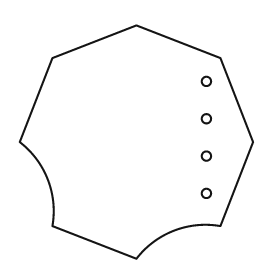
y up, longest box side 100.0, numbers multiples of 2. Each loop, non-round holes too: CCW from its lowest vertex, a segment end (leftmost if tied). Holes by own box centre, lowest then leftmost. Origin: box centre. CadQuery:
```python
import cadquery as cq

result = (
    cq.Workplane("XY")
    .moveTo(0.0, -50.0)
    .threePointArc((16.0, -38.0), (36.0, -36.0))
    .lineTo(50.0, 0.0)
    .lineTo(36.0, 36.0)
    .lineTo(0.0, 50.0)
    .lineTo(-36.0, 36.0)
    .lineTo(-50.0, 0.0)
    .threePointArc((-38.0, -16.0), (-36.0, -36.0))
    .close()
    .moveTo(30.0, -22.0)
    .circle(2.0)
    .moveTo(30.0, -6.0)
    .circle(2.0)
    .moveTo(30.0, 10.0)
    .circle(2.0)
    .moveTo(30.0, 26.0)
    .circle(2.0)
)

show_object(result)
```